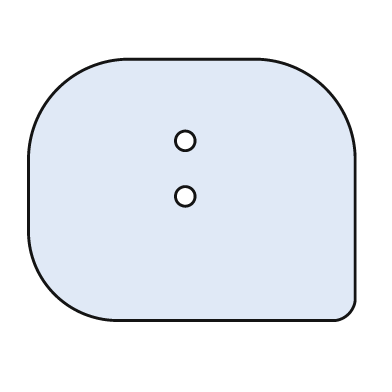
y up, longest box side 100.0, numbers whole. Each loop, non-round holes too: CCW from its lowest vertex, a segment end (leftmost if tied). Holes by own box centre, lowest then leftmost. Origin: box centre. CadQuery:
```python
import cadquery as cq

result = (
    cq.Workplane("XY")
    .moveTo(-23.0, -40.0)
    .lineTo(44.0, -40.0)
    .threePointArc((48.0, -38.0), (50.0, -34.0))
    .lineTo(50.0, 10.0)
    .threePointArc((41.0, 31.0), (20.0, 40.0))
    .lineTo(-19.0, 40.0)
    .threePointArc((-41.0, 31.0), (-50.0, 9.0))
    .lineTo(-50.0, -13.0)
    .threePointArc((-42.0, -32.0), (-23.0, -40.0))
    .close()
    .moveTo(-2.0, -2.0)
    .circle(3.0)
    .moveTo(-2.0, 15.0)
    .circle(3.0)
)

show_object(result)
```